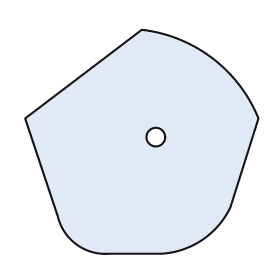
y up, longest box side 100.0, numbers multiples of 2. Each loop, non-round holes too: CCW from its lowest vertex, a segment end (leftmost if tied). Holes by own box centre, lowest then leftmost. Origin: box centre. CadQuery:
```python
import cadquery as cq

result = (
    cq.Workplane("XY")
    .moveTo(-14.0, -48.0)
    .lineTo(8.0, -48.0)
    .threePointArc((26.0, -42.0), (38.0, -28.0))
    .lineTo(50.0, 10.0)
    .threePointArc((30.0, 36.0), (0.0, 48.0))
    .lineTo(-50.0, 10.0)
    .lineTo(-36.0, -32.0)
    .threePointArc((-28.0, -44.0), (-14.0, -48.0))
    .close()
    .moveTo(6.0, 2.0)
    .circle(4.0)
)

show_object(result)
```